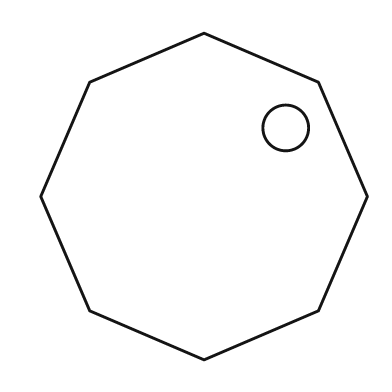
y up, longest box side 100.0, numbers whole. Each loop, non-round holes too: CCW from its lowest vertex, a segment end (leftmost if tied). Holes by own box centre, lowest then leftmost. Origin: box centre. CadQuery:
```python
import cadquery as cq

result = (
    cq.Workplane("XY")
    .moveTo(0.0, -50.0)
    .lineTo(35.0, -35.0)
    .lineTo(50.0, 0.0)
    .lineTo(35.0, 35.0)
    .lineTo(0.0, 50.0)
    .lineTo(-35.0, 35.0)
    .lineTo(-50.0, 0.0)
    .lineTo(-35.0, -35.0)
    .close()
    .moveTo(25.0, 21.0)
    .circle(7.0)
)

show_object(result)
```